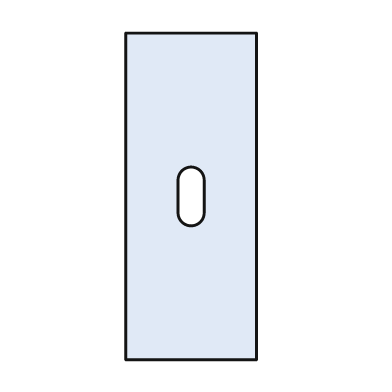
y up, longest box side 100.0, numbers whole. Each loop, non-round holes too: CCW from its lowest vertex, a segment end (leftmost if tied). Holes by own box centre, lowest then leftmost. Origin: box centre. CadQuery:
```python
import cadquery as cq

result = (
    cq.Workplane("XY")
    .moveTo(-20.0, -50.0)
    .lineTo(20.0, -50.0)
    .lineTo(20.0, 50.0)
    .lineTo(-20.0, 50.0)
    .close()
    .moveTo(-4.0, -5.0)
    .threePointArc((0.0, -9.0), (4.0, -5.0))
    .lineTo(4.0, 5.0)
    .threePointArc((0.0, 9.0), (-4.0, 5.0))
    .close()
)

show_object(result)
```